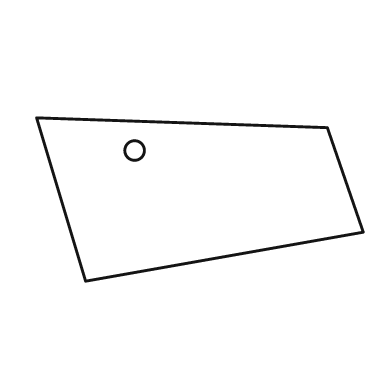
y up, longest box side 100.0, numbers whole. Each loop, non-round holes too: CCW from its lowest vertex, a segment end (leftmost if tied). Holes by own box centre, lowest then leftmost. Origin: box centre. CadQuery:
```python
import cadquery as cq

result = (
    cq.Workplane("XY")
    .moveTo(-35.0, -25.0)
    .lineTo(50.0, -10.0)
    .lineTo(39.0, 22.0)
    .lineTo(-50.0, 25.0)
    .close()
    .moveTo(-20.0, 15.0)
    .circle(3.0)
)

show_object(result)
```